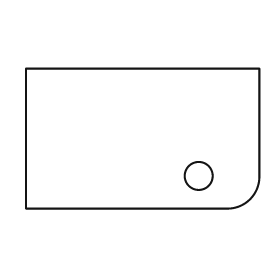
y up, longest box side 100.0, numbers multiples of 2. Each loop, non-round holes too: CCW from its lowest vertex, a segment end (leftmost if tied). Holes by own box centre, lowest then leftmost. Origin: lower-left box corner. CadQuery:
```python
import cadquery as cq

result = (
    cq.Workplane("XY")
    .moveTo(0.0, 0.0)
    .lineTo(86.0, 0.0)
    .threePointArc((96.0, 4.0), (100.0, 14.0))
    .lineTo(100.0, 60.0)
    .lineTo(0.0, 60.0)
    .close()
    .moveTo(74.0, 14.0)
    .circle(6.0)
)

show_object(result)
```